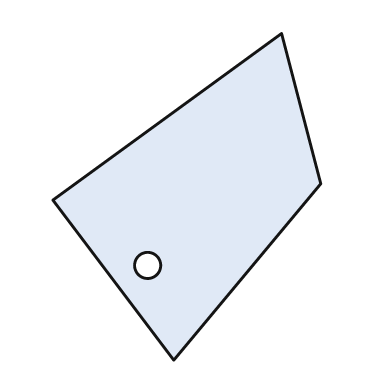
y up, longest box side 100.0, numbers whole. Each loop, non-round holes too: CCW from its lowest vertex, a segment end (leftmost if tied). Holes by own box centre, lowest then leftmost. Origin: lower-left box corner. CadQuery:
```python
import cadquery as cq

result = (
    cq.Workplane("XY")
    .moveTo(37.0, 0.0)
    .lineTo(82.0, 54.0)
    .lineTo(70.0, 100.0)
    .lineTo(0.0, 49.0)
    .close()
    .moveTo(29.0, 29.0)
    .circle(4.0)
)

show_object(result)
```